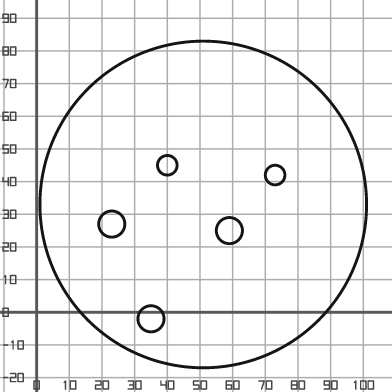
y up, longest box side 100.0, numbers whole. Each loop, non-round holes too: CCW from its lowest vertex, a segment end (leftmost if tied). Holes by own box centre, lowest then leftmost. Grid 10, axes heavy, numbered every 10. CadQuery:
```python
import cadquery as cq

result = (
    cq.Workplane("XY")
    .moveTo(51.0, 33.0)
    .circle(50.0)
    .moveTo(35.0, -2.0)
    .circle(4.0)
    .moveTo(59.0, 25.0)
    .circle(4.0)
    .moveTo(23.0, 27.0)
    .circle(4.0)
    .moveTo(73.0, 42.0)
    .circle(3.0)
    .moveTo(40.0, 45.0)
    .circle(3.0)
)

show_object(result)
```